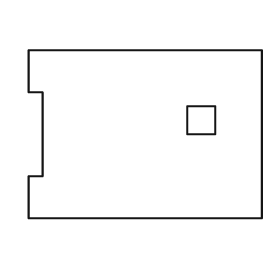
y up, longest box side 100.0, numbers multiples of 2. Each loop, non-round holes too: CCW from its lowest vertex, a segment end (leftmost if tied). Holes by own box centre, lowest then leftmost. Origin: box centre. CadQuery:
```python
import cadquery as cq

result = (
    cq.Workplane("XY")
    .moveTo(-50.0, -36.0)
    .lineTo(50.0, -36.0)
    .lineTo(50.0, 36.0)
    .lineTo(-50.0, 36.0)
    .lineTo(-50.0, 18.0)
    .lineTo(-44.0, 18.0)
    .lineTo(-44.0, -18.0)
    .lineTo(-50.0, -18.0)
    .close()
    .moveTo(18.0, 0.0)
    .lineTo(30.0, 0.0)
    .lineTo(30.0, 12.0)
    .lineTo(18.0, 12.0)
    .close()
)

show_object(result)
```